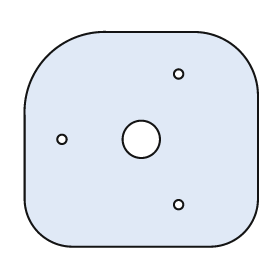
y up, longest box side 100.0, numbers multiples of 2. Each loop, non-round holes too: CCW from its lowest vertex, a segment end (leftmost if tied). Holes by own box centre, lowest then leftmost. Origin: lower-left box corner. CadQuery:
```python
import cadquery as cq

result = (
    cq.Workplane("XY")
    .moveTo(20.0, 0.0)
    .lineTo(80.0, 0.0)
    .threePointArc((94.0, 6.0), (100.0, 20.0))
    .lineTo(100.0, 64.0)
    .threePointArc((92.0, 84.0), (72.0, 92.0))
    .lineTo(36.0, 92.0)
    .threePointArc((10.0, 82.0), (0.0, 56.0))
    .lineTo(0.0, 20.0)
    .threePointArc((6.0, 6.0), (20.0, 0.0))
    .close()
    .moveTo(66.0, 18.0)
    .circle(2.0)
    .moveTo(16.0, 46.0)
    .circle(2.0)
    .moveTo(50.0, 46.0)
    .circle(8.0)
    .moveTo(66.0, 74.0)
    .circle(2.0)
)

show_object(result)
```